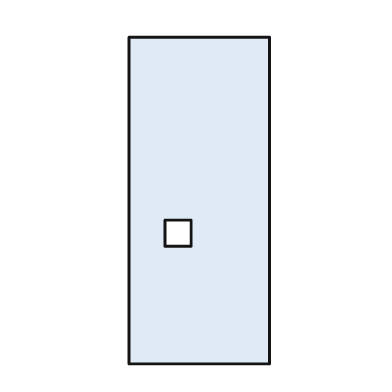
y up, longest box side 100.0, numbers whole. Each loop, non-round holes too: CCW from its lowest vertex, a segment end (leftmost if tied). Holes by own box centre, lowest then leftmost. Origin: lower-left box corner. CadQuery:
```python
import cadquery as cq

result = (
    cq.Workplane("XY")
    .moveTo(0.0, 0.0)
    .lineTo(43.0, 0.0)
    .lineTo(43.0, 100.0)
    .lineTo(0.0, 100.0)
    .close()
    .moveTo(11.0, 36.0)
    .lineTo(19.0, 36.0)
    .lineTo(19.0, 44.0)
    .lineTo(11.0, 44.0)
    .close()
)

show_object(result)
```